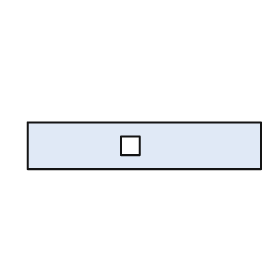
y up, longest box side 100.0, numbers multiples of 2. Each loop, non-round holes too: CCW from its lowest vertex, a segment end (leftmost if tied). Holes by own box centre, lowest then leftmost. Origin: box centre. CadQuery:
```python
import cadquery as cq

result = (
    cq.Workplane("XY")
    .moveTo(-50.0, -10.0)
    .lineTo(50.0, -10.0)
    .lineTo(50.0, 10.0)
    .lineTo(-50.0, 10.0)
    .close()
    .moveTo(-10.0, -4.0)
    .lineTo(-2.0, -4.0)
    .lineTo(-2.0, 4.0)
    .lineTo(-10.0, 4.0)
    .close()
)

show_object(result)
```